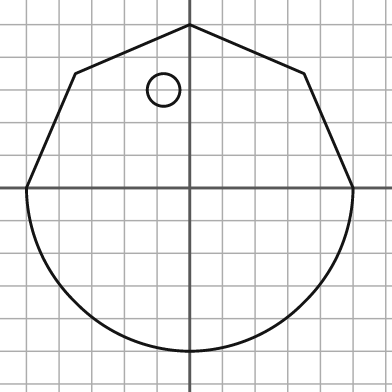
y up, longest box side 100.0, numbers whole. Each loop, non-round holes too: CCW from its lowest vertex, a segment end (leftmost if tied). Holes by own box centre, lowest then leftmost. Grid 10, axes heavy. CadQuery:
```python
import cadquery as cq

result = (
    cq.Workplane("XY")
    .moveTo(0.0, -50.0)
    .threePointArc((19.0, -46.0), (35.0, -35.0))
    .threePointArc((46.0, -19.0), (50.0, 0.0))
    .lineTo(35.0, 35.0)
    .lineTo(0.0, 50.0)
    .lineTo(-35.0, 35.0)
    .lineTo(-50.0, 0.0)
    .threePointArc((-46.0, -19.0), (-35.0, -35.0))
    .threePointArc((-19.0, -46.0), (0.0, -50.0))
    .close()
    .moveTo(-8.0, 30.0)
    .circle(5.0)
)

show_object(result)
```